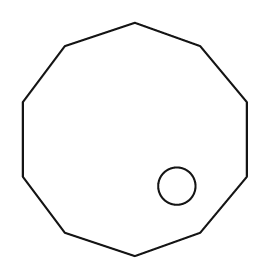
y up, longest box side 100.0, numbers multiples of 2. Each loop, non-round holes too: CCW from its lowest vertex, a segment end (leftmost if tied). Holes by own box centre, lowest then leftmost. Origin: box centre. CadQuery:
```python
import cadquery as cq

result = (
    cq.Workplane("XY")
    .moveTo(0.0, -50.0)
    .lineTo(28.0, -40.0)
    .lineTo(48.0, -16.0)
    .lineTo(48.0, 16.0)
    .lineTo(28.0, 40.0)
    .lineTo(0.0, 50.0)
    .lineTo(-30.0, 40.0)
    .lineTo(-48.0, 16.0)
    .lineTo(-48.0, -16.0)
    .lineTo(-30.0, -40.0)
    .close()
    .moveTo(18.0, -20.0)
    .circle(8.0)
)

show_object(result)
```